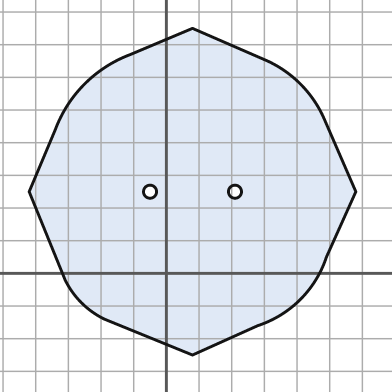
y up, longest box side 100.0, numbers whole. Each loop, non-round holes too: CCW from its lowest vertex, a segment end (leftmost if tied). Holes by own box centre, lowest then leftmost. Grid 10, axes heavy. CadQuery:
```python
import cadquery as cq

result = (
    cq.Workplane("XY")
    .moveTo(8.0, -25.0)
    .lineTo(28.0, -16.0)
    .threePointArc((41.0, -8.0), (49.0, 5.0))
    .lineTo(58.0, 25.0)
    .lineTo(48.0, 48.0)
    .threePointArc((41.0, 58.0), (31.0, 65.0))
    .lineTo(8.0, 75.0)
    .lineTo(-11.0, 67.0)
    .threePointArc((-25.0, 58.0), (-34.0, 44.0))
    .lineTo(-42.0, 25.0)
    .lineTo(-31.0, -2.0)
    .threePointArc((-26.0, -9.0), (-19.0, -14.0))
    .close()
    .moveTo(-5.0, 25.0)
    .circle(2.0)
    .moveTo(21.0, 25.0)
    .circle(2.0)
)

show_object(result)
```